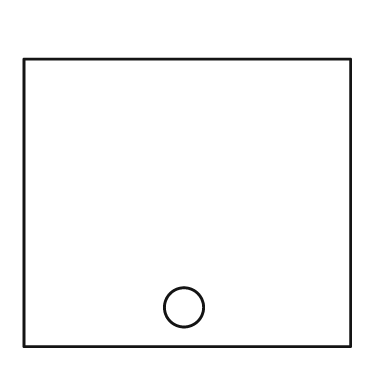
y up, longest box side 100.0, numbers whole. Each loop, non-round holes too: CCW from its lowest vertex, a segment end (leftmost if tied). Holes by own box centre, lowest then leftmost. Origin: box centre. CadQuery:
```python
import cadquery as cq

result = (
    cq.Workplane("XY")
    .moveTo(-50.0, -44.0)
    .lineTo(50.0, -44.0)
    .lineTo(50.0, 44.0)
    .lineTo(-50.0, 44.0)
    .close()
    .moveTo(-1.0, -32.0)
    .circle(6.0)
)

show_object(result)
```